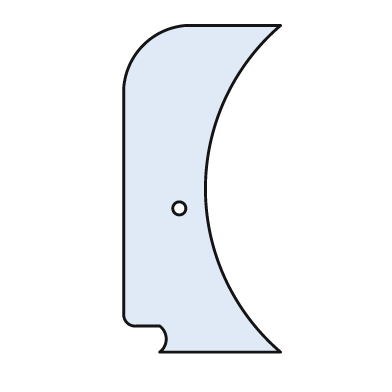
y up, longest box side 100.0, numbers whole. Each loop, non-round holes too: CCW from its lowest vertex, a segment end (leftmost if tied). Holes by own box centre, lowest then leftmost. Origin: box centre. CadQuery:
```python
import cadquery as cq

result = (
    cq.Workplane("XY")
    .moveTo(-13.0, -50.0)
    .lineTo(24.0, -50.0)
    .threePointArc((1.0, 0.0), (24.0, 50.0))
    .lineTo(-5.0, 50.0)
    .threePointArc((-18.0, 44.0), (-24.0, 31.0))
    .lineTo(-24.0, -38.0)
    .threePointArc((-23.0, -41.0), (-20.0, -42.0))
    .lineTo(-13.0, -42.0)
    .threePointArc((-11.0, -46.0), (-13.0, -50.0))
    .close()
    .moveTo(-7.0, -6.0)
    .circle(2.0)
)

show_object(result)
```